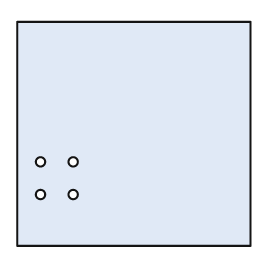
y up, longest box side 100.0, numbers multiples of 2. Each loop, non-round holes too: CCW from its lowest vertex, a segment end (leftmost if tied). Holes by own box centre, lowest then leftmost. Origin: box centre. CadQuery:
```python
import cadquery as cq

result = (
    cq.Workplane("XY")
    .moveTo(-50.0, -48.0)
    .lineTo(50.0, -48.0)
    .lineTo(50.0, 48.0)
    .lineTo(-50.0, 48.0)
    .close()
    .moveTo(-40.0, -26.0)
    .circle(2.0)
    .moveTo(-26.0, -26.0)
    .circle(2.0)
    .moveTo(-40.0, -12.0)
    .circle(2.0)
    .moveTo(-26.0, -12.0)
    .circle(2.0)
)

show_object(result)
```